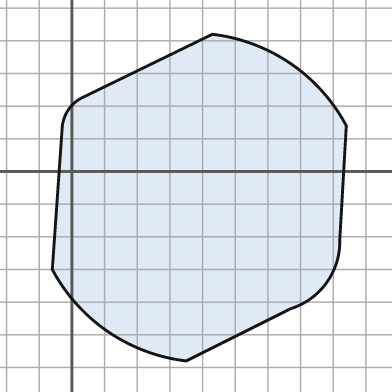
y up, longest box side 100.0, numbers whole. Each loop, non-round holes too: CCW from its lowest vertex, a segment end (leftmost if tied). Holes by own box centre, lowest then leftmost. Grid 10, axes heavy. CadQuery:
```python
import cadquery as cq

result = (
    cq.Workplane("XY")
    .moveTo(35.0, -58.0)
    .lineTo(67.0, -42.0)
    .threePointArc((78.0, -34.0), (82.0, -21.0))
    .lineTo(84.0, 14.0)
    .threePointArc((67.0, 33.0), (43.0, 42.0))
    .lineTo(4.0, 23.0)
    .threePointArc((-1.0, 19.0), (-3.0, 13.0))
    .lineTo(-6.0, -30.0)
    .threePointArc((11.0, -49.0), (35.0, -58.0))
    .close()
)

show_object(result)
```